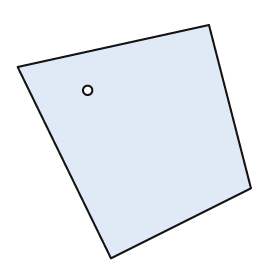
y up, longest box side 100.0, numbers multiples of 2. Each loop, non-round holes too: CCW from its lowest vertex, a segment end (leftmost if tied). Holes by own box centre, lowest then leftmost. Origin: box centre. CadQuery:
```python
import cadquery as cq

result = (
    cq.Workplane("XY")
    .moveTo(-10.0, -50.0)
    .lineTo(50.0, -20.0)
    .lineTo(32.0, 50.0)
    .lineTo(-50.0, 32.0)
    .close()
    .moveTo(-20.0, 22.0)
    .circle(2.0)
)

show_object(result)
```